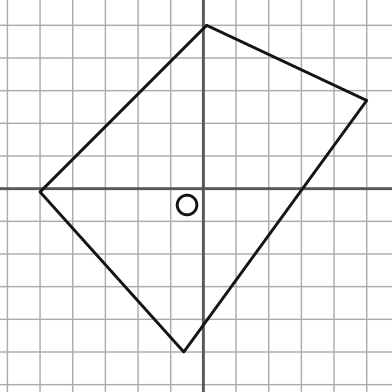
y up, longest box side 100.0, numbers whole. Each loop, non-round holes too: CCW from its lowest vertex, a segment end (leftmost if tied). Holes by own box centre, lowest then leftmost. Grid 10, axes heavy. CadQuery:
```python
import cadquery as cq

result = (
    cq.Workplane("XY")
    .moveTo(-6.0, -50.0)
    .lineTo(50.0, 27.0)
    .lineTo(1.0, 50.0)
    .lineTo(-50.0, -1.0)
    .close()
    .moveTo(-5.0, -5.0)
    .circle(3.0)
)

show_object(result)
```